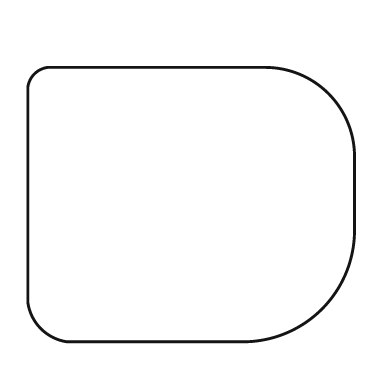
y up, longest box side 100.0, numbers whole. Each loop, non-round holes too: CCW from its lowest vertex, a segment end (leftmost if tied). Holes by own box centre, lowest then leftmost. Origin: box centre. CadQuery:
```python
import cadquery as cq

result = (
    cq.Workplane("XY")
    .moveTo(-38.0, -42.0)
    .lineTo(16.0, -42.0)
    .threePointArc((40.0, -32.0), (50.0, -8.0))
    .lineTo(50.0, 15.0)
    .threePointArc((42.0, 34.0), (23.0, 42.0))
    .lineTo(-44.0, 42.0)
    .threePointArc((-48.0, 40.0), (-50.0, 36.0))
    .lineTo(-50.0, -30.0)
    .threePointArc((-46.0, -38.0), (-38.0, -42.0))
    .close()
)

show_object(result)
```